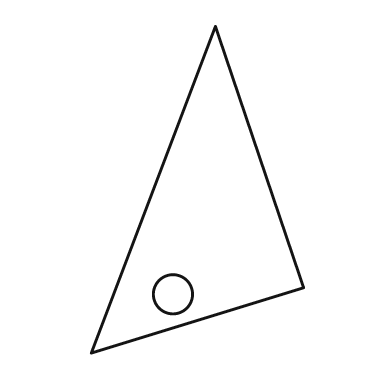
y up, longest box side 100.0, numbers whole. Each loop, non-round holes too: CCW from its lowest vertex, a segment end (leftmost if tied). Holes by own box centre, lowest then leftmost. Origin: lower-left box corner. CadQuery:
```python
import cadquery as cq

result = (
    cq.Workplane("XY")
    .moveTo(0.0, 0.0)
    .lineTo(65.0, 20.0)
    .lineTo(38.0, 100.0)
    .close()
    .moveTo(25.0, 18.0)
    .circle(6.0)
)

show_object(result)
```